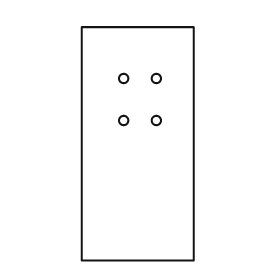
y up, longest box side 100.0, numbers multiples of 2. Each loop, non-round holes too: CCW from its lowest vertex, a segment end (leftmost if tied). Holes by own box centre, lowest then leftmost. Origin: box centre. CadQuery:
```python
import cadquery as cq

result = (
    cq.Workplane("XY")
    .moveTo(-24.0, -50.0)
    .lineTo(24.0, -50.0)
    .lineTo(24.0, 50.0)
    .lineTo(-24.0, 50.0)
    .close()
    .moveTo(-6.0, 10.0)
    .circle(2.0)
    .moveTo(8.0, 10.0)
    .circle(2.0)
    .moveTo(-6.0, 28.0)
    .circle(2.0)
    .moveTo(8.0, 28.0)
    .circle(2.0)
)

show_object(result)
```